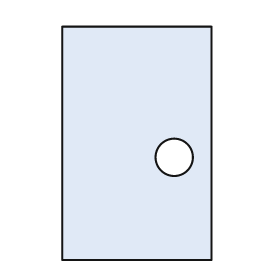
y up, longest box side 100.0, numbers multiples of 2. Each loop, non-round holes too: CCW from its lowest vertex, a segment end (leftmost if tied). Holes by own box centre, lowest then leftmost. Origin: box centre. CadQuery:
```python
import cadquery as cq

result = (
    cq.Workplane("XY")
    .moveTo(-32.0, -50.0)
    .lineTo(32.0, -50.0)
    .lineTo(32.0, 50.0)
    .lineTo(-32.0, 50.0)
    .close()
    .moveTo(16.0, -6.0)
    .circle(8.0)
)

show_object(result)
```